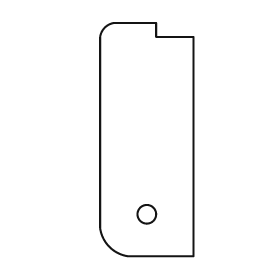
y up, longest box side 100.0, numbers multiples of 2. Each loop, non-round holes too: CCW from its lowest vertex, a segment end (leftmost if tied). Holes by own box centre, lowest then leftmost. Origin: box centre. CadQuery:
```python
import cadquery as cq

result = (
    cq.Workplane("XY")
    .moveTo(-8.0, -50.0)
    .lineTo(20.0, -50.0)
    .lineTo(20.0, 44.0)
    .lineTo(4.0, 44.0)
    .lineTo(4.0, 50.0)
    .lineTo(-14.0, 50.0)
    .threePointArc((-18.0, 48.0), (-20.0, 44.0))
    .lineTo(-20.0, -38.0)
    .threePointArc((-16.0, -46.0), (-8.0, -50.0))
    .close()
    .moveTo(0.0, -32.0)
    .circle(4.0)
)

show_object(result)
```